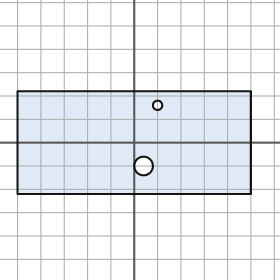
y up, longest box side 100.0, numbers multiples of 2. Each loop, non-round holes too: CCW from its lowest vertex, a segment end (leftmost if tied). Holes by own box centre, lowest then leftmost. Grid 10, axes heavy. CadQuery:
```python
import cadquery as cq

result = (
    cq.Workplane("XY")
    .moveTo(-50.0, -22.0)
    .lineTo(50.0, -22.0)
    .lineTo(50.0, 22.0)
    .lineTo(-50.0, 22.0)
    .close()
    .moveTo(4.0, -10.0)
    .circle(4.0)
    .moveTo(10.0, 16.0)
    .circle(2.0)
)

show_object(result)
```